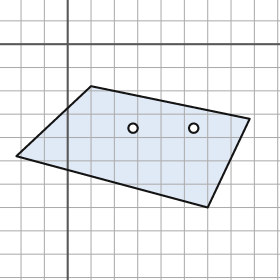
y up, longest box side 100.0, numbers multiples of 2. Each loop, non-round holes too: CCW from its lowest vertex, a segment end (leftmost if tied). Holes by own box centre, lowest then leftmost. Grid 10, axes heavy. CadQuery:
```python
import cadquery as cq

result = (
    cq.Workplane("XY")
    .moveTo(60.0, -70.0)
    .lineTo(78.0, -32.0)
    .lineTo(10.0, -18.0)
    .lineTo(-22.0, -48.0)
    .close()
    .moveTo(28.0, -36.0)
    .circle(2.0)
    .moveTo(54.0, -36.0)
    .circle(2.0)
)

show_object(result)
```